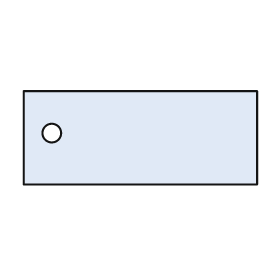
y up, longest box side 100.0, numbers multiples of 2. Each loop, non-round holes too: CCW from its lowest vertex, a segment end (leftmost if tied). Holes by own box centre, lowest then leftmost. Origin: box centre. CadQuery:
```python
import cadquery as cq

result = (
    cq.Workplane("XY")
    .moveTo(-50.0, -20.0)
    .lineTo(50.0, -20.0)
    .lineTo(50.0, 20.0)
    .lineTo(-50.0, 20.0)
    .close()
    .moveTo(-38.0, 2.0)
    .circle(4.0)
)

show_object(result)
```